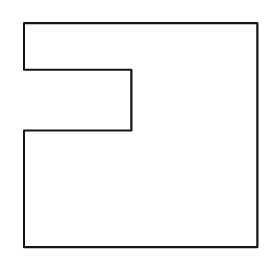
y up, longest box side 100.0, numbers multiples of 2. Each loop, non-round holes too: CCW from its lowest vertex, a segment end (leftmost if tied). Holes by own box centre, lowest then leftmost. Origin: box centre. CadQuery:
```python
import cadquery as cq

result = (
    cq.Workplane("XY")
    .moveTo(-50.0, -48.0)
    .lineTo(50.0, -48.0)
    .lineTo(50.0, 48.0)
    .lineTo(-50.0, 48.0)
    .lineTo(-50.0, 28.0)
    .lineTo(-4.0, 28.0)
    .lineTo(-4.0, 2.0)
    .lineTo(-50.0, 2.0)
    .close()
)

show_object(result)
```